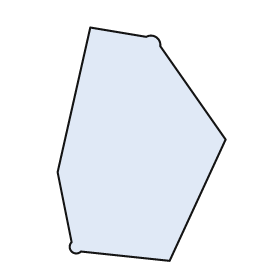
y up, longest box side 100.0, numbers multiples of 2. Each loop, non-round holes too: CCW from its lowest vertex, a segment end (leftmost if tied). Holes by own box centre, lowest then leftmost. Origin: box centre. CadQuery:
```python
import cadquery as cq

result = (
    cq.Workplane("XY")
    .moveTo(12.0, -50.0)
    .lineTo(36.0, 2.0)
    .lineTo(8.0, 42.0)
    .threePointArc((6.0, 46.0), (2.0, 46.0))
    .lineTo(-22.0, 50.0)
    .lineTo(-36.0, -12.0)
    .lineTo(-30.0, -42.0)
    .threePointArc((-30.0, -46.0), (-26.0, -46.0))
    .close()
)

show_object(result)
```